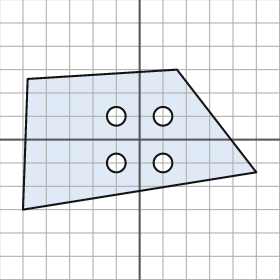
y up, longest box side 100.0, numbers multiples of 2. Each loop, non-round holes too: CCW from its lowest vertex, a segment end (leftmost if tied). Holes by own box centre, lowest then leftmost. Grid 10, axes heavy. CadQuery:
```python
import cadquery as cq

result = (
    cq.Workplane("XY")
    .moveTo(-50.0, -30.0)
    .lineTo(50.0, -14.0)
    .lineTo(16.0, 30.0)
    .lineTo(-48.0, 26.0)
    .close()
    .moveTo(-10.0, -10.0)
    .circle(4.0)
    .moveTo(10.0, -10.0)
    .circle(4.0)
    .moveTo(-10.0, 10.0)
    .circle(4.0)
    .moveTo(10.0, 10.0)
    .circle(4.0)
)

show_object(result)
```